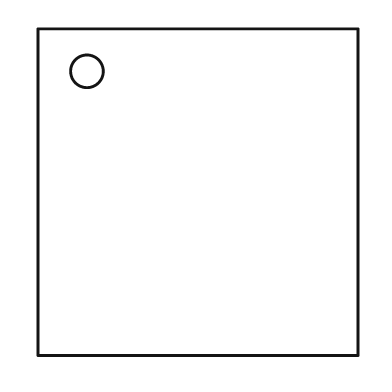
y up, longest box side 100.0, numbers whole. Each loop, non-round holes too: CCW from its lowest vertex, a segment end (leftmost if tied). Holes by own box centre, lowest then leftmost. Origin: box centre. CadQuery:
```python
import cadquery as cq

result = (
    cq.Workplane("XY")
    .moveTo(-49.0, -50.0)
    .lineTo(49.0, -50.0)
    .lineTo(49.0, 50.0)
    .lineTo(-49.0, 50.0)
    .close()
    .moveTo(-34.0, 37.0)
    .circle(5.0)
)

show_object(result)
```